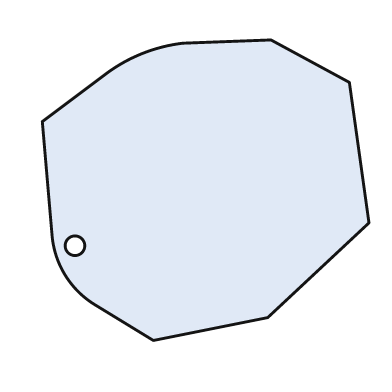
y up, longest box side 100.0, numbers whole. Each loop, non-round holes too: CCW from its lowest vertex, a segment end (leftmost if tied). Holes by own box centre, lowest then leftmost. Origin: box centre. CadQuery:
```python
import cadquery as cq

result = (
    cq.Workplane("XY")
    .moveTo(-16.0, -46.0)
    .lineTo(19.0, -39.0)
    .lineTo(50.0, -10.0)
    .lineTo(44.0, 33.0)
    .lineTo(20.0, 46.0)
    .lineTo(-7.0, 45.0)
    .threePointArc((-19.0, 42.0), (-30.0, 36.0))
    .lineTo(-50.0, 21.0)
    .lineTo(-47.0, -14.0)
    .threePointArc((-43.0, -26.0), (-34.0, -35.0))
    .close()
    .moveTo(-40.0, -17.0)
    .circle(3.0)
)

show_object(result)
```